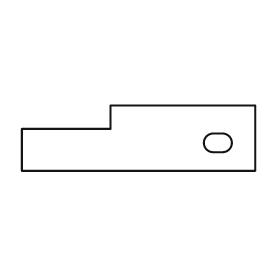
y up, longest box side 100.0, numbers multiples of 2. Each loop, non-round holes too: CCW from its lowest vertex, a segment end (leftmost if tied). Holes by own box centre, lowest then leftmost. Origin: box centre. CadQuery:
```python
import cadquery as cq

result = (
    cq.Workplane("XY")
    .moveTo(-50.0, -14.0)
    .lineTo(50.0, -14.0)
    .lineTo(50.0, 14.0)
    .lineTo(-12.0, 14.0)
    .lineTo(-12.0, 4.0)
    .lineTo(-50.0, 4.0)
    .close()
    .moveTo(32.0, -6.0)
    .lineTo(36.0, -6.0)
    .threePointArc((40.0, -2.0), (36.0, 2.0))
    .lineTo(32.0, 2.0)
    .threePointArc((28.0, -2.0), (32.0, -6.0))
    .close()
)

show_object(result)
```